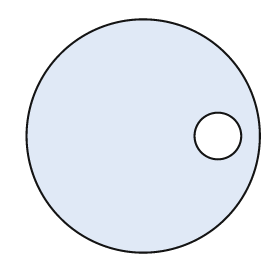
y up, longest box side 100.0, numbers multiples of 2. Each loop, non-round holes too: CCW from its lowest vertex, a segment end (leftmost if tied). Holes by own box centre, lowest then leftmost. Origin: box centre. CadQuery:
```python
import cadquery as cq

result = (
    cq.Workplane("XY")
    .moveTo(0.0, 0.0)
    .circle(50.0)
    .moveTo(32.0, 0.0)
    .circle(10.0)
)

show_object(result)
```